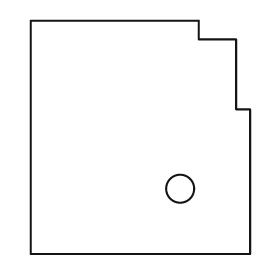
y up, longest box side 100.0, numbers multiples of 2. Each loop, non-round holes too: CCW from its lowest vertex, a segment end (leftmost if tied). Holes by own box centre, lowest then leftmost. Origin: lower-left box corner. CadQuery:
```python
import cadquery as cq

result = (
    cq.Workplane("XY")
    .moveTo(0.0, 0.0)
    .lineTo(94.0, 0.0)
    .lineTo(94.0, 62.0)
    .lineTo(88.0, 62.0)
    .lineTo(88.0, 92.0)
    .lineTo(72.0, 92.0)
    .lineTo(72.0, 100.0)
    .lineTo(0.0, 100.0)
    .close()
    .moveTo(64.0, 28.0)
    .circle(6.0)
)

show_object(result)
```